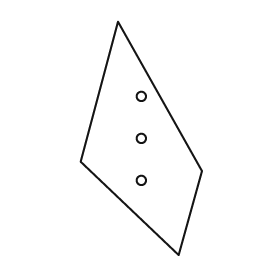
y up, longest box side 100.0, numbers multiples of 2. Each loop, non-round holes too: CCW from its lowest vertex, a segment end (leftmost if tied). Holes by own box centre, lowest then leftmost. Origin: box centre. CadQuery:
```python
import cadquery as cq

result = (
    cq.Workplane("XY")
    .moveTo(16.0, -50.0)
    .lineTo(26.0, -14.0)
    .lineTo(-10.0, 50.0)
    .lineTo(-26.0, -10.0)
    .close()
    .moveTo(0.0, -18.0)
    .circle(2.0)
    .moveTo(0.0, 0.0)
    .circle(2.0)
    .moveTo(0.0, 18.0)
    .circle(2.0)
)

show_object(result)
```